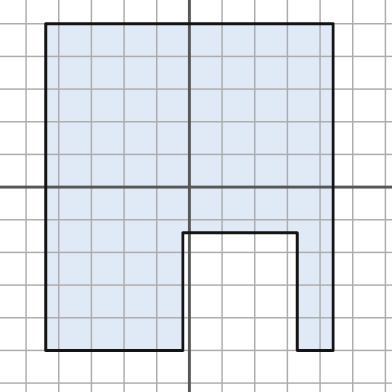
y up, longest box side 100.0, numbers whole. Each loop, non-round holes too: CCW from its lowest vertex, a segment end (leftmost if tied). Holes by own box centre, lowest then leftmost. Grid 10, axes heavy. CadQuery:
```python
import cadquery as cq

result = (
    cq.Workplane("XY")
    .moveTo(-44.0, -50.0)
    .lineTo(-2.0, -50.0)
    .lineTo(-2.0, -14.0)
    .lineTo(33.0, -14.0)
    .lineTo(33.0, -50.0)
    .lineTo(44.0, -50.0)
    .lineTo(44.0, 50.0)
    .lineTo(-44.0, 50.0)
    .close()
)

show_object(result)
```